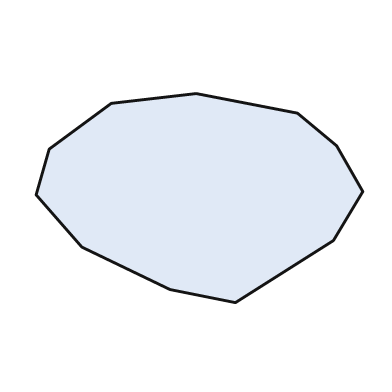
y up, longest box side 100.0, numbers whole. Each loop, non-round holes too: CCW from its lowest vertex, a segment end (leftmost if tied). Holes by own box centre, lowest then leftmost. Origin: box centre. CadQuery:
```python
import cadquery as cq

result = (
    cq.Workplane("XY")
    .moveTo(11.0, -32.0)
    .lineTo(41.0, -13.0)
    .lineTo(50.0, 2.0)
    .lineTo(42.0, 16.0)
    .lineTo(30.0, 26.0)
    .lineTo(-1.0, 32.0)
    .lineTo(-27.0, 29.0)
    .lineTo(-46.0, 15.0)
    .lineTo(-50.0, 1.0)
    .lineTo(-36.0, -15.0)
    .lineTo(-9.0, -28.0)
    .close()
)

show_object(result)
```